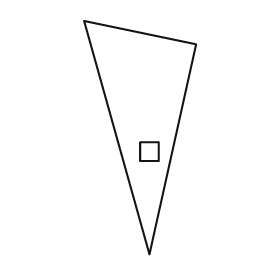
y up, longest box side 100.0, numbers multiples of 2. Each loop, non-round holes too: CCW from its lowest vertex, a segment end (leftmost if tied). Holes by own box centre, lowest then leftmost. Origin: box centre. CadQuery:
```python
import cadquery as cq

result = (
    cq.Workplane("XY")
    .moveTo(4.0, -50.0)
    .lineTo(24.0, 40.0)
    .lineTo(-24.0, 50.0)
    .close()
    .moveTo(0.0, -10.0)
    .lineTo(8.0, -10.0)
    .lineTo(8.0, -2.0)
    .lineTo(0.0, -2.0)
    .close()
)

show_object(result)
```